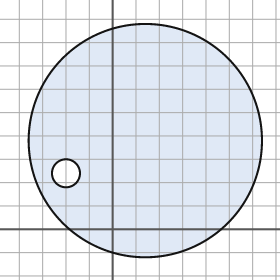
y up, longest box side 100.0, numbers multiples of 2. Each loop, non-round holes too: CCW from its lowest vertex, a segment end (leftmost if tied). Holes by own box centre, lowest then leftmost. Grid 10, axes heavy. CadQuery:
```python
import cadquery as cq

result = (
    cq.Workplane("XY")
    .moveTo(14.0, 38.0)
    .circle(50.0)
    .moveTo(-20.0, 24.0)
    .circle(6.0)
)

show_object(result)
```